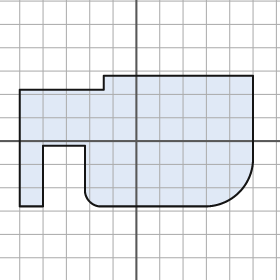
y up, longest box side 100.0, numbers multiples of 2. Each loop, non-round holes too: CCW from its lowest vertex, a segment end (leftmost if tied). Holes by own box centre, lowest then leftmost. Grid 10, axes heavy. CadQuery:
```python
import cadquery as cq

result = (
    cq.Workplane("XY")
    .moveTo(-50.0, -28.0)
    .lineTo(-40.0, -28.0)
    .lineTo(-40.0, -2.0)
    .lineTo(-22.0, -2.0)
    .lineTo(-22.0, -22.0)
    .threePointArc((-20.0, -26.0), (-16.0, -28.0))
    .lineTo(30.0, -28.0)
    .threePointArc((44.0, -22.0), (50.0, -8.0))
    .lineTo(50.0, 28.0)
    .lineTo(-14.0, 28.0)
    .lineTo(-14.0, 22.0)
    .lineTo(-50.0, 22.0)
    .close()
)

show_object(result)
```